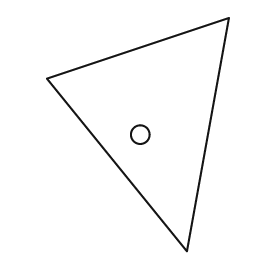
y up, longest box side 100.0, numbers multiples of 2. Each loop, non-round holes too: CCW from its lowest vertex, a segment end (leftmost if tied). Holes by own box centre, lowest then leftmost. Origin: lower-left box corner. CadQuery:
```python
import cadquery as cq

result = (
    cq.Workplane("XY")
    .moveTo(60.0, 0.0)
    .lineTo(78.0, 100.0)
    .lineTo(0.0, 74.0)
    .close()
    .moveTo(40.0, 50.0)
    .circle(4.0)
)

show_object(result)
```